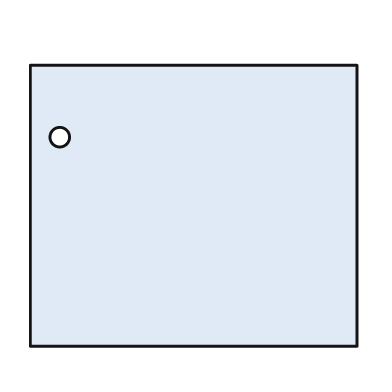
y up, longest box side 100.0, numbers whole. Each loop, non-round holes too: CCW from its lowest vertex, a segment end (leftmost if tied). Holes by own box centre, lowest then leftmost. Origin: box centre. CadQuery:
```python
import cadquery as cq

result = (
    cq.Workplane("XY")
    .moveTo(-50.0, -43.0)
    .lineTo(50.0, -43.0)
    .lineTo(50.0, 43.0)
    .lineTo(-50.0, 43.0)
    .close()
    .moveTo(-41.0, 21.0)
    .circle(3.0)
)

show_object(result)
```